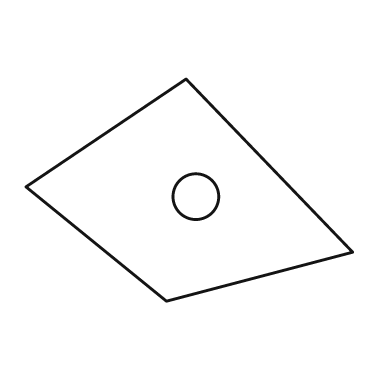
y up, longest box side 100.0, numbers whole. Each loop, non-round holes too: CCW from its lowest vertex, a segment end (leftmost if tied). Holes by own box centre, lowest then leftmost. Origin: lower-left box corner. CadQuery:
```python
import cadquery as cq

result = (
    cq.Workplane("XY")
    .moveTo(43.0, 0.0)
    .lineTo(100.0, 15.0)
    .lineTo(49.0, 68.0)
    .lineTo(0.0, 35.0)
    .close()
    .moveTo(52.0, 32.0)
    .circle(7.0)
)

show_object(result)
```